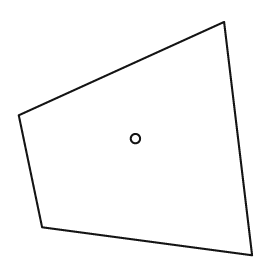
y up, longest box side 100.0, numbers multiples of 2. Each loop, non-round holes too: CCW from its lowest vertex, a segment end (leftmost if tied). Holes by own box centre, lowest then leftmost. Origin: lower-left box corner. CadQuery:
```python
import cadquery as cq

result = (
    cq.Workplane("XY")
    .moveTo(100.0, 0.0)
    .lineTo(88.0, 100.0)
    .lineTo(0.0, 60.0)
    .lineTo(10.0, 12.0)
    .close()
    .moveTo(50.0, 50.0)
    .circle(2.0)
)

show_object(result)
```